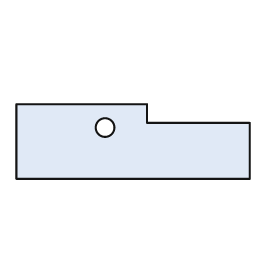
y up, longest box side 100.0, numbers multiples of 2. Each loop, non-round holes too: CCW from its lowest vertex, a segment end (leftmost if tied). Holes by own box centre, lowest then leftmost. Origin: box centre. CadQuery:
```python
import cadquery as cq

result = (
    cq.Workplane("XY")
    .moveTo(-50.0, -16.0)
    .lineTo(50.0, -16.0)
    .lineTo(50.0, 8.0)
    .lineTo(6.0, 8.0)
    .lineTo(6.0, 16.0)
    .lineTo(-50.0, 16.0)
    .close()
    .moveTo(-12.0, 6.0)
    .circle(4.0)
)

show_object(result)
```